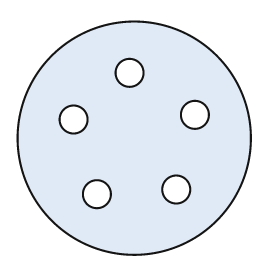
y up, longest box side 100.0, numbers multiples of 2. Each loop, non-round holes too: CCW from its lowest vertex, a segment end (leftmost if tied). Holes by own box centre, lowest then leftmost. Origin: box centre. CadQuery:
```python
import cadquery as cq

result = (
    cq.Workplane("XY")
    .moveTo(0.0, 0.0)
    .circle(50.0)
    .moveTo(-16.0, -24.0)
    .circle(6.0)
    .moveTo(18.0, -22.0)
    .circle(6.0)
    .moveTo(-26.0, 8.0)
    .circle(6.0)
    .moveTo(26.0, 10.0)
    .circle(6.0)
    .moveTo(-2.0, 28.0)
    .circle(6.0)
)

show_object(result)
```